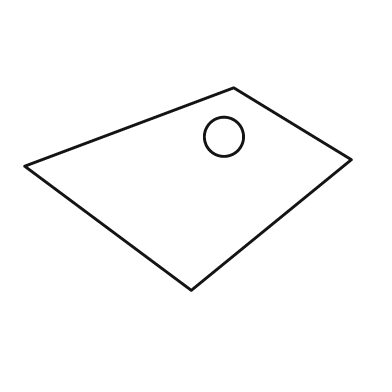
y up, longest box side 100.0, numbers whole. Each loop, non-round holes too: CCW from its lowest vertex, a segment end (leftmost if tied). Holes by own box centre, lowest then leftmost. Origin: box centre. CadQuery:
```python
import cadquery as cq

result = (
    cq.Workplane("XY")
    .moveTo(1.0, -31.0)
    .lineTo(50.0, 9.0)
    .lineTo(14.0, 31.0)
    .lineTo(-50.0, 7.0)
    .close()
    .moveTo(11.0, 16.0)
    .circle(6.0)
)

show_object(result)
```